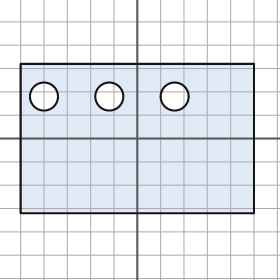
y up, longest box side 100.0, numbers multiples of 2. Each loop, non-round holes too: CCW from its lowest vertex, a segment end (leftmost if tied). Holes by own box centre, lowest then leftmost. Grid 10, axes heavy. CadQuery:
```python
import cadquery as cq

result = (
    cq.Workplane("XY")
    .moveTo(-50.0, -32.0)
    .lineTo(50.0, -32.0)
    .lineTo(50.0, 32.0)
    .lineTo(-50.0, 32.0)
    .close()
    .moveTo(-40.0, 18.0)
    .circle(6.0)
    .moveTo(-12.0, 18.0)
    .circle(6.0)
    .moveTo(16.0, 18.0)
    .circle(6.0)
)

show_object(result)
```